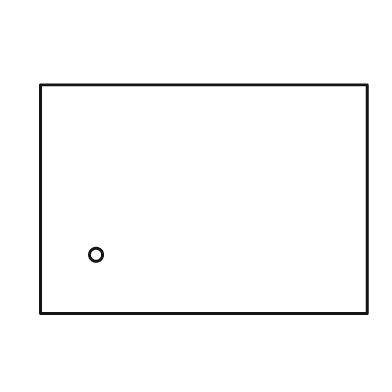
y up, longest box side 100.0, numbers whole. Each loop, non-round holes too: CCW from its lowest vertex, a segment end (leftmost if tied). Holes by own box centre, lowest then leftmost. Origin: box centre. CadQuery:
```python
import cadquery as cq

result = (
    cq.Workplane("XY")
    .moveTo(-50.0, -35.0)
    .lineTo(50.0, -35.0)
    .lineTo(50.0, 35.0)
    .lineTo(-50.0, 35.0)
    .close()
    .moveTo(-33.0, -17.0)
    .circle(2.0)
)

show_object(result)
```